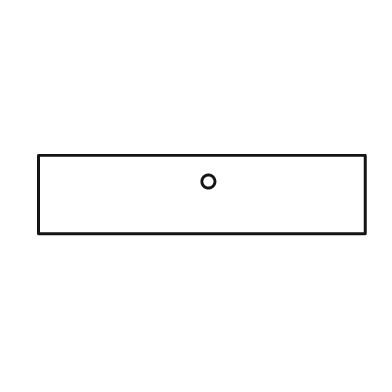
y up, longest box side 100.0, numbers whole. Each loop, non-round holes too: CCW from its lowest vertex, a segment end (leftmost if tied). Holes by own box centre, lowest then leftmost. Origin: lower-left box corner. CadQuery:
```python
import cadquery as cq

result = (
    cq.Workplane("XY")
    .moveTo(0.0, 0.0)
    .lineTo(100.0, 0.0)
    .lineTo(100.0, 24.0)
    .lineTo(0.0, 24.0)
    .close()
    .moveTo(52.0, 16.0)
    .circle(2.0)
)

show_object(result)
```